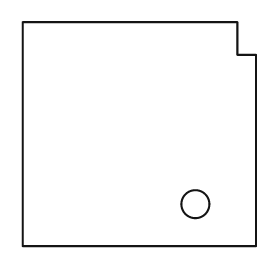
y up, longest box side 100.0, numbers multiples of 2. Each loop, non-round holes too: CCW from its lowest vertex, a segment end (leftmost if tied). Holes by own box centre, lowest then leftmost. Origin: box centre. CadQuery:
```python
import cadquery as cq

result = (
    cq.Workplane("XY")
    .moveTo(-50.0, -48.0)
    .lineTo(50.0, -48.0)
    .lineTo(50.0, 34.0)
    .lineTo(42.0, 34.0)
    .lineTo(42.0, 48.0)
    .lineTo(-50.0, 48.0)
    .close()
    .moveTo(24.0, -30.0)
    .circle(6.0)
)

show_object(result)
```